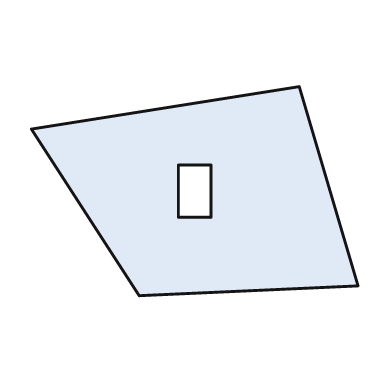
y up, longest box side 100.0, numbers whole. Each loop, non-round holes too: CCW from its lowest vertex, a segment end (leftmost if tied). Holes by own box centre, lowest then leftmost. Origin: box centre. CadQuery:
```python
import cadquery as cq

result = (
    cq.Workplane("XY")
    .moveTo(-17.0, -32.0)
    .lineTo(50.0, -29.0)
    .lineTo(32.0, 32.0)
    .lineTo(-50.0, 19.0)
    .close()
    .moveTo(-5.0, -8.0)
    .lineTo(5.0, -8.0)
    .lineTo(5.0, 8.0)
    .lineTo(-5.0, 8.0)
    .close()
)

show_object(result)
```